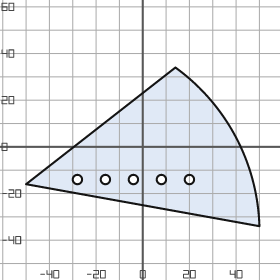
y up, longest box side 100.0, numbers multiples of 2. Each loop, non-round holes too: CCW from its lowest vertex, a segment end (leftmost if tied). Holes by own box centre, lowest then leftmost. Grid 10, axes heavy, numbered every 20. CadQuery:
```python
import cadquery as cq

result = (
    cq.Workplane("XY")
    .moveTo(50.0, -34.0)
    .threePointArc((40.0, 4.0), (14.0, 34.0))
    .lineTo(-50.0, -16.0)
    .close()
    .moveTo(-28.0, -14.0)
    .circle(2.0)
    .moveTo(-16.0, -14.0)
    .circle(2.0)
    .moveTo(-4.0, -14.0)
    .circle(2.0)
    .moveTo(8.0, -14.0)
    .circle(2.0)
    .moveTo(20.0, -14.0)
    .circle(2.0)
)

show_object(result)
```